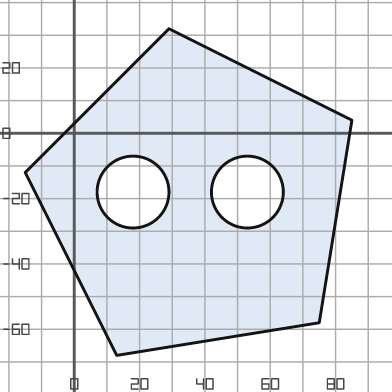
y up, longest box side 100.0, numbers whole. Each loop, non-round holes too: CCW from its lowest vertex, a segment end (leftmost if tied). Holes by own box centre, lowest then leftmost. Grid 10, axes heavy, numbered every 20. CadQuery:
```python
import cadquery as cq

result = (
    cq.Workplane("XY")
    .moveTo(13.0, -68.0)
    .lineTo(75.0, -58.0)
    .lineTo(85.0, 4.0)
    .lineTo(29.0, 32.0)
    .lineTo(-15.0, -12.0)
    .close()
    .moveTo(18.0, -18.0)
    .circle(11.0)
    .moveTo(53.0, -18.0)
    .circle(11.0)
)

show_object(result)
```